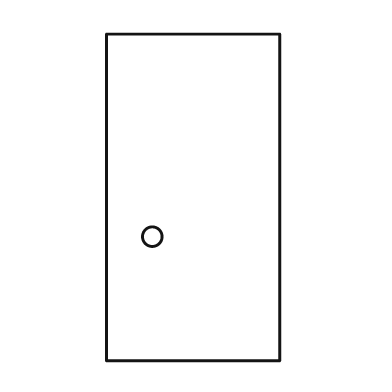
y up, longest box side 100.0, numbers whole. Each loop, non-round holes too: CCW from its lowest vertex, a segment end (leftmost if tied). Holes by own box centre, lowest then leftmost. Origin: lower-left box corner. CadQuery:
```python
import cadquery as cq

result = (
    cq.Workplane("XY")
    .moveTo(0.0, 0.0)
    .lineTo(53.0, 0.0)
    .lineTo(53.0, 100.0)
    .lineTo(0.0, 100.0)
    .close()
    .moveTo(14.0, 38.0)
    .circle(3.0)
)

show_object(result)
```